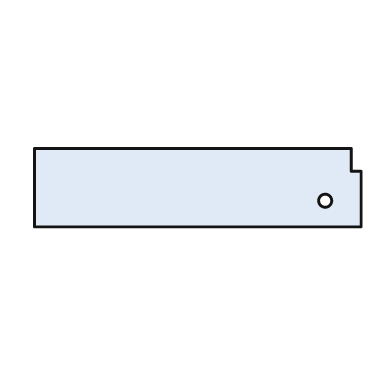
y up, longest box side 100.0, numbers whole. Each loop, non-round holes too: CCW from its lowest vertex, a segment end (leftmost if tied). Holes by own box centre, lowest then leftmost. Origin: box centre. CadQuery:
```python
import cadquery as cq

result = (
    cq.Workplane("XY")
    .moveTo(-50.0, -12.0)
    .lineTo(50.0, -12.0)
    .lineTo(50.0, 5.0)
    .lineTo(47.0, 5.0)
    .lineTo(47.0, 12.0)
    .lineTo(-50.0, 12.0)
    .close()
    .moveTo(39.0, -4.0)
    .circle(2.0)
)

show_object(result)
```